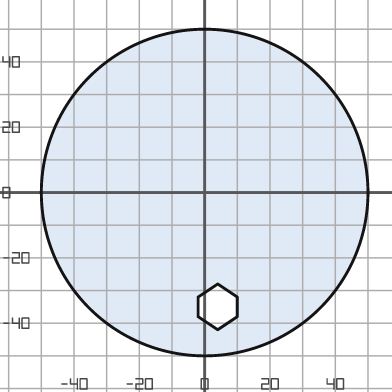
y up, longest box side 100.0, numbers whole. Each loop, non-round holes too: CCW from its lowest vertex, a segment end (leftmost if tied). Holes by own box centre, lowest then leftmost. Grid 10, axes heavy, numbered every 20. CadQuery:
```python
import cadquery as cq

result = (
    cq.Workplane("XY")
    .moveTo(0.0, 0.0)
    .circle(50.0)
    .moveTo(4.0, -42.0)
    .lineTo(10.0, -38.0)
    .lineTo(10.0, -32.0)
    .lineTo(4.0, -28.0)
    .lineTo(-2.0, -32.0)
    .lineTo(-2.0, -38.0)
    .close()
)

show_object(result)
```